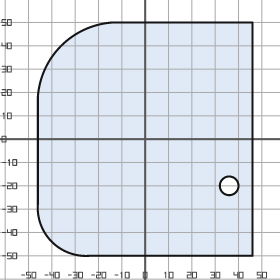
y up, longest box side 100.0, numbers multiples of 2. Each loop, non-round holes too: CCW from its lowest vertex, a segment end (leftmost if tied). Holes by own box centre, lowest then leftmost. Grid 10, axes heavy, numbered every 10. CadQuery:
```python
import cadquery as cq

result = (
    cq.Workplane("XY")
    .moveTo(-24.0, -50.0)
    .lineTo(46.0, -50.0)
    .lineTo(46.0, 50.0)
    .lineTo(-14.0, 50.0)
    .threePointArc((-36.0, 40.0), (-46.0, 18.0))
    .lineTo(-46.0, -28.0)
    .threePointArc((-40.0, -44.0), (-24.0, -50.0))
    .close()
    .moveTo(36.0, -20.0)
    .circle(4.0)
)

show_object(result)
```